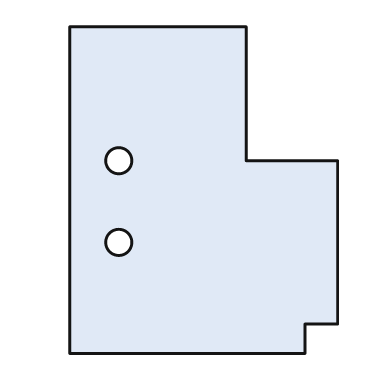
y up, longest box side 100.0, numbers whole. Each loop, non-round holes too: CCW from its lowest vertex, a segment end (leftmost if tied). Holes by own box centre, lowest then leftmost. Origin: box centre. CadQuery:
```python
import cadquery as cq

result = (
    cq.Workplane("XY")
    .moveTo(-41.0, -50.0)
    .lineTo(31.0, -50.0)
    .lineTo(31.0, -41.0)
    .lineTo(41.0, -41.0)
    .lineTo(41.0, 9.0)
    .lineTo(13.0, 9.0)
    .lineTo(13.0, 50.0)
    .lineTo(-41.0, 50.0)
    .close()
    .moveTo(-26.0, -16.0)
    .circle(4.0)
    .moveTo(-26.0, 9.0)
    .circle(4.0)
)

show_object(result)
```